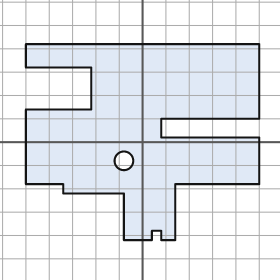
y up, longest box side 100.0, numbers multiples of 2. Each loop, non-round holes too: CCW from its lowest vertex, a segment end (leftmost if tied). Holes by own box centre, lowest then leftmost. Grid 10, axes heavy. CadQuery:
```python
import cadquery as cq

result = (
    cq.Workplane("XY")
    .moveTo(-8.0, -42.0)
    .lineTo(4.0, -42.0)
    .lineTo(4.0, -38.0)
    .lineTo(8.0, -38.0)
    .lineTo(8.0, -42.0)
    .lineTo(14.0, -42.0)
    .lineTo(14.0, -18.0)
    .lineTo(50.0, -18.0)
    .lineTo(50.0, 2.0)
    .lineTo(8.0, 2.0)
    .lineTo(8.0, 10.0)
    .lineTo(50.0, 10.0)
    .lineTo(50.0, 42.0)
    .lineTo(-50.0, 42.0)
    .lineTo(-50.0, 32.0)
    .lineTo(-22.0, 32.0)
    .lineTo(-22.0, 14.0)
    .lineTo(-50.0, 14.0)
    .lineTo(-50.0, -18.0)
    .lineTo(-34.0, -18.0)
    .lineTo(-34.0, -22.0)
    .lineTo(-8.0, -22.0)
    .close()
    .moveTo(-8.0, -8.0)
    .circle(4.0)
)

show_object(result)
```